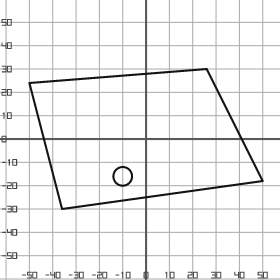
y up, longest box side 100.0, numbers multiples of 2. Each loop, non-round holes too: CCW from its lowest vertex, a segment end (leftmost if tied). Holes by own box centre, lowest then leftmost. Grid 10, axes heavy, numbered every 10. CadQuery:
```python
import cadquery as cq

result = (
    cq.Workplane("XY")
    .moveTo(-36.0, -30.0)
    .lineTo(50.0, -18.0)
    .lineTo(26.0, 30.0)
    .lineTo(-50.0, 24.0)
    .close()
    .moveTo(-10.0, -16.0)
    .circle(4.0)
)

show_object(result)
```